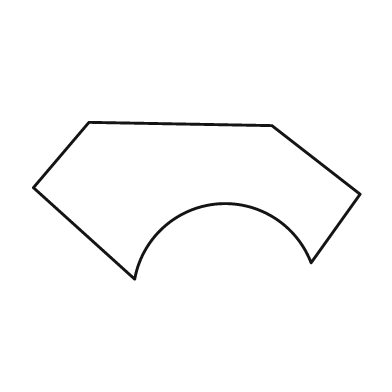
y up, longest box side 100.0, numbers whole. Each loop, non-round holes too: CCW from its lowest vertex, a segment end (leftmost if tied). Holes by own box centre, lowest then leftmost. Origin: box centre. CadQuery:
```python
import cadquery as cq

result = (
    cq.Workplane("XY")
    .moveTo(-19.0, -24.0)
    .threePointArc((6.0, -1.0), (35.0, -19.0))
    .lineTo(50.0, 2.0)
    .lineTo(23.0, 23.0)
    .lineTo(-33.0, 24.0)
    .lineTo(-50.0, 4.0)
    .close()
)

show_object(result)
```